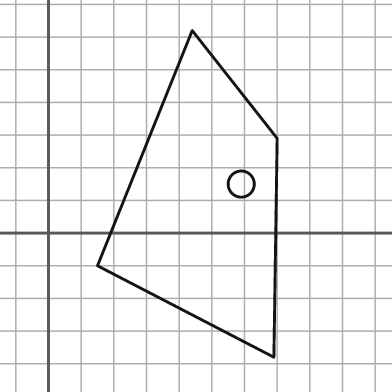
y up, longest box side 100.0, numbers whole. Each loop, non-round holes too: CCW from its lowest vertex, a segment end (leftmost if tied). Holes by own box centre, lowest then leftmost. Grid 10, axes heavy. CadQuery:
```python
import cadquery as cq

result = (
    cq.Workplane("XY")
    .moveTo(69.0, -38.0)
    .lineTo(70.0, 29.0)
    .lineTo(44.0, 62.0)
    .lineTo(15.0, -10.0)
    .close()
    .moveTo(59.0, 15.0)
    .circle(4.0)
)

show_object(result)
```